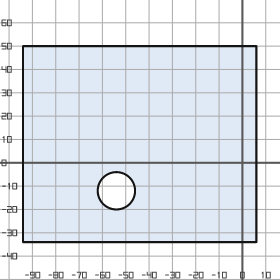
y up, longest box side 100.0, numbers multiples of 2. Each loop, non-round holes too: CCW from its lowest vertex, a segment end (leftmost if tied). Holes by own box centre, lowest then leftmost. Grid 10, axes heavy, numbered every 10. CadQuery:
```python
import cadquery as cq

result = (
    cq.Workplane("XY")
    .moveTo(-94.0, -34.0)
    .lineTo(6.0, -34.0)
    .lineTo(6.0, 50.0)
    .lineTo(-94.0, 50.0)
    .close()
    .moveTo(-54.0, -12.0)
    .circle(8.0)
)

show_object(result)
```